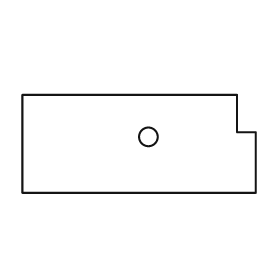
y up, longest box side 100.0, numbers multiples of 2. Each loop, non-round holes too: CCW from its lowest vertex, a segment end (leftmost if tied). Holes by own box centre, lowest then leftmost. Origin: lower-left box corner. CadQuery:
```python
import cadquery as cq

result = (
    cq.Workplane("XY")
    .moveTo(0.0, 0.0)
    .lineTo(100.0, 0.0)
    .lineTo(100.0, 26.0)
    .lineTo(92.0, 26.0)
    .lineTo(92.0, 42.0)
    .lineTo(0.0, 42.0)
    .close()
    .moveTo(54.0, 24.0)
    .circle(4.0)
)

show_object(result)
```